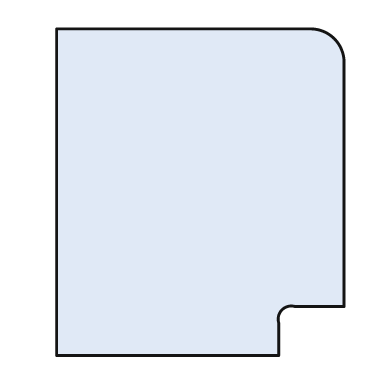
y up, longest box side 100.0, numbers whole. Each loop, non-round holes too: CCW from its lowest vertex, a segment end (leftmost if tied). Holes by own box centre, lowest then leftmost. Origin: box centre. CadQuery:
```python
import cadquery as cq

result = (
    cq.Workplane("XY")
    .moveTo(-44.0, -50.0)
    .lineTo(24.0, -50.0)
    .lineTo(24.0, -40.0)
    .threePointArc((25.0, -36.0), (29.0, -35.0))
    .lineTo(44.0, -35.0)
    .lineTo(44.0, 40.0)
    .threePointArc((41.0, 47.0), (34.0, 50.0))
    .lineTo(-44.0, 50.0)
    .close()
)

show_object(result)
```